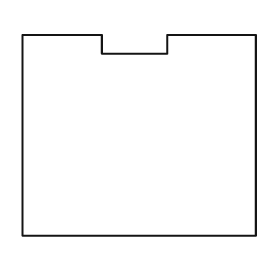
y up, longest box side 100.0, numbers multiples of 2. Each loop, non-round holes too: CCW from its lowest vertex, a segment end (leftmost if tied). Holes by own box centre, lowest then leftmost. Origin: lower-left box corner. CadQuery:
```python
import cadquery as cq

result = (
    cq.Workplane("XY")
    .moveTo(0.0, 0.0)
    .lineTo(100.0, 0.0)
    .lineTo(100.0, 86.0)
    .lineTo(62.0, 86.0)
    .lineTo(62.0, 78.0)
    .lineTo(34.0, 78.0)
    .lineTo(34.0, 86.0)
    .lineTo(0.0, 86.0)
    .close()
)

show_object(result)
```